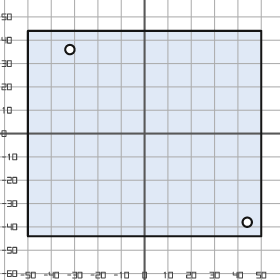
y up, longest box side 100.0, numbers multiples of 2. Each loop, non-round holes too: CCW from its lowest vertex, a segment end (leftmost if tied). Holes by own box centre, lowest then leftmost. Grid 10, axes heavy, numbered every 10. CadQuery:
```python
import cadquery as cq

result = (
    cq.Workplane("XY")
    .moveTo(-50.0, -44.0)
    .lineTo(50.0, -44.0)
    .lineTo(50.0, 44.0)
    .lineTo(-50.0, 44.0)
    .close()
    .moveTo(44.0, -38.0)
    .circle(2.0)
    .moveTo(-32.0, 36.0)
    .circle(2.0)
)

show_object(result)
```